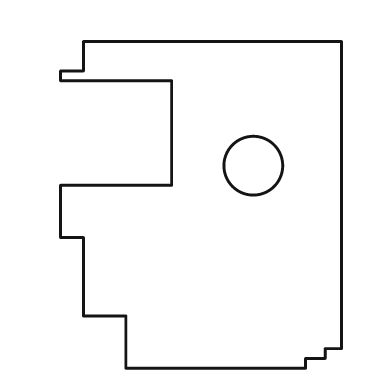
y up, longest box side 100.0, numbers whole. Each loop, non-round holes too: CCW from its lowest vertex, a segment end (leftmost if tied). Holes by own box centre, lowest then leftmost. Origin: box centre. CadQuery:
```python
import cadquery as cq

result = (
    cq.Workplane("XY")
    .moveTo(-23.0, -50.0)
    .lineTo(32.0, -50.0)
    .lineTo(32.0, -47.0)
    .lineTo(38.0, -47.0)
    .lineTo(38.0, -44.0)
    .lineTo(43.0, -44.0)
    .lineTo(43.0, 50.0)
    .lineTo(-36.0, 50.0)
    .lineTo(-36.0, 41.0)
    .lineTo(-43.0, 41.0)
    .lineTo(-43.0, 38.0)
    .lineTo(-9.0, 38.0)
    .lineTo(-9.0, 6.0)
    .lineTo(-43.0, 6.0)
    .lineTo(-43.0, -10.0)
    .lineTo(-36.0, -10.0)
    .lineTo(-36.0, -34.0)
    .lineTo(-23.0, -34.0)
    .close()
    .moveTo(16.0, 12.0)
    .circle(9.0)
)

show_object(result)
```